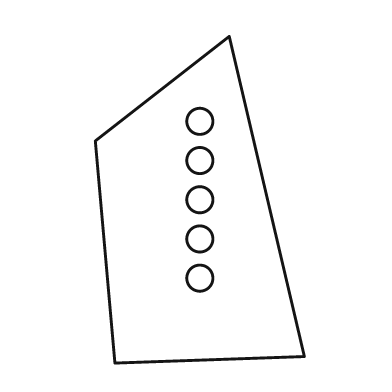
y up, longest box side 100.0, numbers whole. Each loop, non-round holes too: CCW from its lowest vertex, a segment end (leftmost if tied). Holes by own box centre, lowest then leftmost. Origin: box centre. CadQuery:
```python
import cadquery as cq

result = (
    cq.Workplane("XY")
    .moveTo(-26.0, -50.0)
    .lineTo(32.0, -48.0)
    .lineTo(9.0, 50.0)
    .lineTo(-32.0, 18.0)
    .close()
    .moveTo(0.0, -24.0)
    .circle(4.0)
    .moveTo(0.0, -12.0)
    .circle(4.0)
    .moveTo(0.0, 0.0)
    .circle(4.0)
    .moveTo(0.0, 12.0)
    .circle(4.0)
    .moveTo(0.0, 24.0)
    .circle(4.0)
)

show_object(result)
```